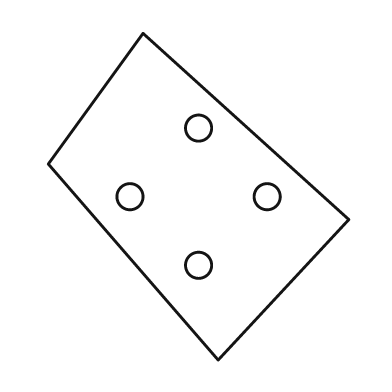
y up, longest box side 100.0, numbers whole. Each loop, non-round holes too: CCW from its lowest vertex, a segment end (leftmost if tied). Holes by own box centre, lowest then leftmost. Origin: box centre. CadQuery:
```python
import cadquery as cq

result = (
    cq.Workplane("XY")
    .moveTo(6.0, -50.0)
    .lineTo(46.0, -7.0)
    .lineTo(-17.0, 50.0)
    .lineTo(-46.0, 10.0)
    .close()
    .moveTo(0.0, -21.0)
    .circle(4.0)
    .moveTo(-21.0, 0.0)
    .circle(4.0)
    .moveTo(21.0, 0.0)
    .circle(4.0)
    .moveTo(0.0, 21.0)
    .circle(4.0)
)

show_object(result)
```